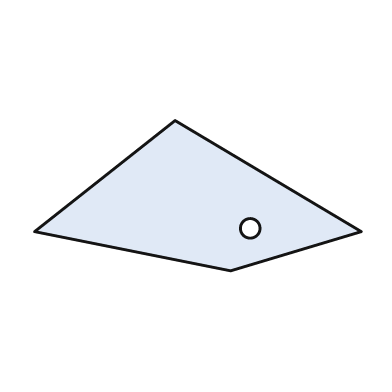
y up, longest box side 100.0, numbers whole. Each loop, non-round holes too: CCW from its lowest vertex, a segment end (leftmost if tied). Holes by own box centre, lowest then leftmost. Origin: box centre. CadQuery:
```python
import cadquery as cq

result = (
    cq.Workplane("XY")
    .moveTo(10.0, -23.0)
    .lineTo(50.0, -11.0)
    .lineTo(-7.0, 23.0)
    .lineTo(-50.0, -11.0)
    .close()
    .moveTo(16.0, -10.0)
    .circle(3.0)
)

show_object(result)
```